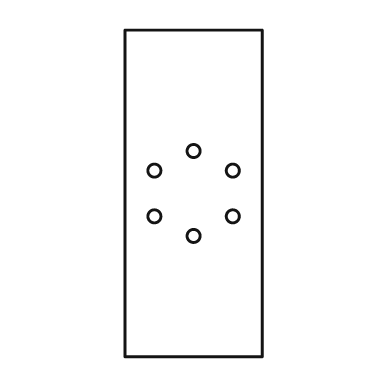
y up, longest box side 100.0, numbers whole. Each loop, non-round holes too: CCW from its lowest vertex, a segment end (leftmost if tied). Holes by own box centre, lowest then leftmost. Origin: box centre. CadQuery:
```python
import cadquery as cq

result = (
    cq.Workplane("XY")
    .moveTo(-21.0, -50.0)
    .lineTo(21.0, -50.0)
    .lineTo(21.0, 50.0)
    .lineTo(-21.0, 50.0)
    .close()
    .moveTo(0.0, -13.0)
    .circle(2.0)
    .moveTo(-12.0, -7.0)
    .circle(2.0)
    .moveTo(12.0, -7.0)
    .circle(2.0)
    .moveTo(-12.0, 7.0)
    .circle(2.0)
    .moveTo(12.0, 7.0)
    .circle(2.0)
    .moveTo(0.0, 13.0)
    .circle(2.0)
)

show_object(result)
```